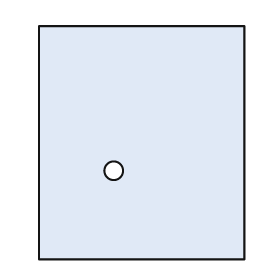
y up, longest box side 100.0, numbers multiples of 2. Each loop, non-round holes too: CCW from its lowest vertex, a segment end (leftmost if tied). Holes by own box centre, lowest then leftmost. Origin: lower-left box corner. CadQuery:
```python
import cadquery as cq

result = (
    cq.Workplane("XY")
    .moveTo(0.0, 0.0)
    .lineTo(88.0, 0.0)
    .lineTo(88.0, 100.0)
    .lineTo(0.0, 100.0)
    .close()
    .moveTo(32.0, 38.0)
    .circle(4.0)
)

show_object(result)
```